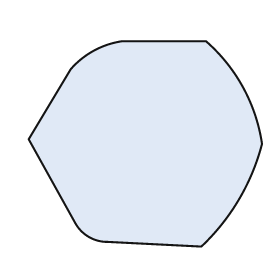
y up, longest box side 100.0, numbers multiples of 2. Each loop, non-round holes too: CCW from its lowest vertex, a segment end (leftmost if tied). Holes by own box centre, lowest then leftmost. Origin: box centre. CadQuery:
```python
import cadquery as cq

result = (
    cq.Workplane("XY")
    .moveTo(24.0, -44.0)
    .threePointArc((40.0, -24.0), (50.0, 0.0))
    .threePointArc((42.0, 24.0), (26.0, 44.0))
    .lineTo(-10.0, 44.0)
    .threePointArc((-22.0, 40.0), (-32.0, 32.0))
    .lineTo(-50.0, 2.0)
    .lineTo(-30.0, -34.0)
    .threePointArc((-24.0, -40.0), (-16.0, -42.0))
    .close()
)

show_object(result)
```